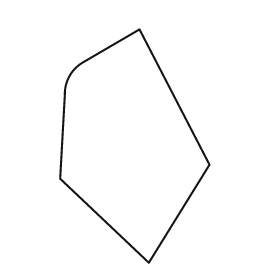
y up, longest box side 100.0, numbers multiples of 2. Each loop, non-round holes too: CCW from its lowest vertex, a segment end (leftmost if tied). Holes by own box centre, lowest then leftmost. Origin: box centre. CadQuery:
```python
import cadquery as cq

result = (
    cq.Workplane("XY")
    .moveTo(6.0, -50.0)
    .lineTo(32.0, -8.0)
    .lineTo(2.0, 50.0)
    .lineTo(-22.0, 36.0)
    .threePointArc((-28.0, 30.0), (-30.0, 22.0))
    .lineTo(-32.0, -14.0)
    .close()
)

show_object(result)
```